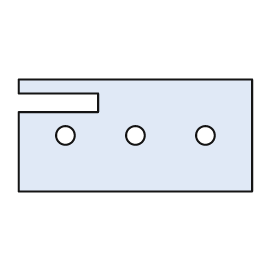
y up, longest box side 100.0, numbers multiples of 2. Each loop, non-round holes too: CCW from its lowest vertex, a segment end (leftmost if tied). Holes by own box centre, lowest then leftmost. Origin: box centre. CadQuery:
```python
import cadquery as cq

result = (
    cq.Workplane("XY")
    .moveTo(-50.0, -24.0)
    .lineTo(50.0, -24.0)
    .lineTo(50.0, 24.0)
    .lineTo(-50.0, 24.0)
    .lineTo(-50.0, 18.0)
    .lineTo(-16.0, 18.0)
    .lineTo(-16.0, 10.0)
    .lineTo(-50.0, 10.0)
    .close()
    .moveTo(-30.0, 0.0)
    .circle(4.0)
    .moveTo(0.0, 0.0)
    .circle(4.0)
    .moveTo(30.0, 0.0)
    .circle(4.0)
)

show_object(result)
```